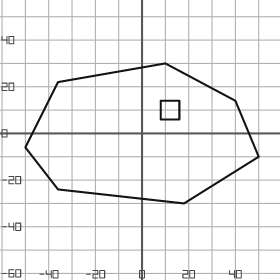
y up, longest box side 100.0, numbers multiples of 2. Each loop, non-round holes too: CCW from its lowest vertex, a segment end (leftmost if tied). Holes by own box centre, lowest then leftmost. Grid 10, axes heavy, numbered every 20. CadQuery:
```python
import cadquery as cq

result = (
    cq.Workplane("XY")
    .moveTo(18.0, -30.0)
    .lineTo(50.0, -10.0)
    .lineTo(40.0, 14.0)
    .lineTo(10.0, 30.0)
    .lineTo(-36.0, 22.0)
    .lineTo(-50.0, -6.0)
    .lineTo(-36.0, -24.0)
    .close()
    .moveTo(8.0, 6.0)
    .lineTo(16.0, 6.0)
    .lineTo(16.0, 14.0)
    .lineTo(8.0, 14.0)
    .close()
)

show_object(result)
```